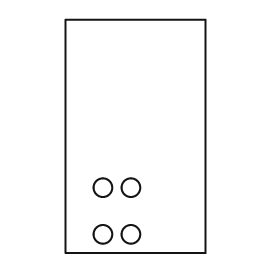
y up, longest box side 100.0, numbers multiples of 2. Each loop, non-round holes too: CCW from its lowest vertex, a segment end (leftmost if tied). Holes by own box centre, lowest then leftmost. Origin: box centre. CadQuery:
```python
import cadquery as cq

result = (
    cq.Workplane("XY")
    .moveTo(-30.0, -50.0)
    .lineTo(30.0, -50.0)
    .lineTo(30.0, 50.0)
    .lineTo(-30.0, 50.0)
    .close()
    .moveTo(-14.0, -42.0)
    .circle(4.0)
    .moveTo(-2.0, -42.0)
    .circle(4.0)
    .moveTo(-14.0, -22.0)
    .circle(4.0)
    .moveTo(-2.0, -22.0)
    .circle(4.0)
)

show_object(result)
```